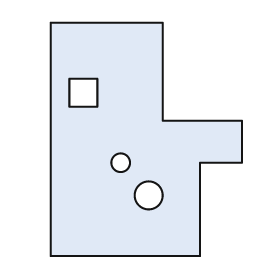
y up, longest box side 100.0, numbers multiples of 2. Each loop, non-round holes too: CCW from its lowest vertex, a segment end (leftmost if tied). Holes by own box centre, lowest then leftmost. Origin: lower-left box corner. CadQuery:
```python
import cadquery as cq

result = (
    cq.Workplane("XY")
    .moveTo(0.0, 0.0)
    .lineTo(64.0, 0.0)
    .lineTo(64.0, 40.0)
    .lineTo(82.0, 40.0)
    .lineTo(82.0, 58.0)
    .lineTo(48.0, 58.0)
    .lineTo(48.0, 100.0)
    .lineTo(0.0, 100.0)
    .close()
    .moveTo(42.0, 26.0)
    .circle(6.0)
    .moveTo(30.0, 40.0)
    .circle(4.0)
    .moveTo(8.0, 64.0)
    .lineTo(20.0, 64.0)
    .lineTo(20.0, 76.0)
    .lineTo(8.0, 76.0)
    .close()
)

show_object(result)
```